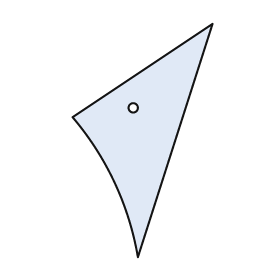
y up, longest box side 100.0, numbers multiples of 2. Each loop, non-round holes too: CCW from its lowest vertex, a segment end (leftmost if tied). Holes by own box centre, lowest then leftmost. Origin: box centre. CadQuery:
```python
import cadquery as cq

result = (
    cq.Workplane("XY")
    .moveTo(-2.0, -50.0)
    .lineTo(30.0, 50.0)
    .lineTo(-30.0, 10.0)
    .threePointArc((-12.0, -18.0), (-2.0, -50.0))
    .close()
    .moveTo(-4.0, 14.0)
    .circle(2.0)
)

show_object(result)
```